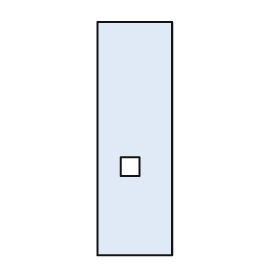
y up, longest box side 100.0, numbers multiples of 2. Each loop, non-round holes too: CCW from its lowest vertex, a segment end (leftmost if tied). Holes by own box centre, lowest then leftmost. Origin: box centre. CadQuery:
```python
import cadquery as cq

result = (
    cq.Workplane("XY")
    .moveTo(-16.0, -50.0)
    .lineTo(16.0, -50.0)
    .lineTo(16.0, 50.0)
    .lineTo(-16.0, 50.0)
    .close()
    .moveTo(-6.0, -16.0)
    .lineTo(2.0, -16.0)
    .lineTo(2.0, -8.0)
    .lineTo(-6.0, -8.0)
    .close()
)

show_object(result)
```